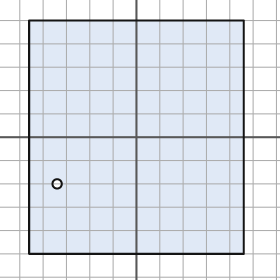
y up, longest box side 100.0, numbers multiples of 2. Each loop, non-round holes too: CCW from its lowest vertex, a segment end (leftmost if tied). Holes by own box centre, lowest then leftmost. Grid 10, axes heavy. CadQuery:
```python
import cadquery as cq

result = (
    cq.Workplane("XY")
    .moveTo(-46.0, -50.0)
    .lineTo(46.0, -50.0)
    .lineTo(46.0, 50.0)
    .lineTo(-46.0, 50.0)
    .close()
    .moveTo(-34.0, -20.0)
    .circle(2.0)
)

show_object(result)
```